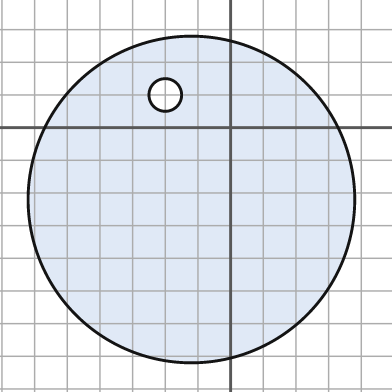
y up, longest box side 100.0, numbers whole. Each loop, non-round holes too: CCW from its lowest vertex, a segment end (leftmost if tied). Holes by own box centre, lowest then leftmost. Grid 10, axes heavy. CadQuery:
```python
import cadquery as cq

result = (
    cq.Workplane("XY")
    .moveTo(-12.0, -22.0)
    .circle(50.0)
    .moveTo(-20.0, 10.0)
    .circle(5.0)
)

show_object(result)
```